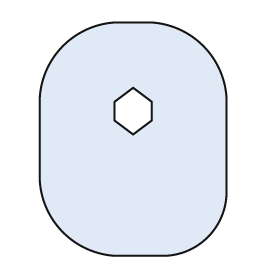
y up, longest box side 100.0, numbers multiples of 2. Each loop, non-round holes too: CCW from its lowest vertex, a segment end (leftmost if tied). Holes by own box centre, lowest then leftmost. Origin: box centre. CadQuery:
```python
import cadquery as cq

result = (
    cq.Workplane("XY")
    .moveTo(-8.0, -50.0)
    .lineTo(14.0, -50.0)
    .threePointArc((32.0, -42.0), (40.0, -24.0))
    .lineTo(40.0, 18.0)
    .threePointArc((30.0, 40.0), (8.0, 50.0))
    .lineTo(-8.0, 50.0)
    .threePointArc((-30.0, 40.0), (-40.0, 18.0))
    .lineTo(-40.0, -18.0)
    .threePointArc((-30.0, -40.0), (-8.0, -50.0))
    .close()
    .moveTo(0.0, 2.0)
    .lineTo(8.0, 8.0)
    .lineTo(8.0, 16.0)
    .lineTo(0.0, 22.0)
    .lineTo(-8.0, 16.0)
    .lineTo(-8.0, 8.0)
    .close()
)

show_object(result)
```